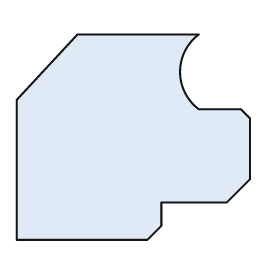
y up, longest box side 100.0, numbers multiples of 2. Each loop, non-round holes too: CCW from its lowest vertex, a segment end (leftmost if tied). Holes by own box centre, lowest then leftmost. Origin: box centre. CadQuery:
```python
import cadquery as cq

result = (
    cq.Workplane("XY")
    .moveTo(-50.0, -44.0)
    .lineTo(6.0, -44.0)
    .lineTo(12.0, -38.0)
    .lineTo(12.0, -28.0)
    .lineTo(40.0, -28.0)
    .lineTo(50.0, -18.0)
    .lineTo(50.0, 8.0)
    .lineTo(46.0, 12.0)
    .lineTo(28.0, 12.0)
    .threePointArc((20.0, 28.0), (28.0, 44.0))
    .lineTo(-24.0, 44.0)
    .lineTo(-50.0, 16.0)
    .close()
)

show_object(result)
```